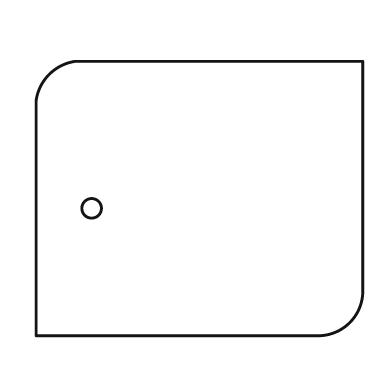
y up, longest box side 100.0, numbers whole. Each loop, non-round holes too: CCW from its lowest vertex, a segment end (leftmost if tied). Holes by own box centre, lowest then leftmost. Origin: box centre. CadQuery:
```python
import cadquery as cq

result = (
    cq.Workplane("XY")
    .moveTo(-50.0, -42.0)
    .lineTo(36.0, -42.0)
    .threePointArc((46.0, -38.0), (50.0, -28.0))
    .lineTo(50.0, 42.0)
    .lineTo(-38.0, 42.0)
    .threePointArc((-46.0, 38.0), (-50.0, 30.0))
    .close()
    .moveTo(-33.0, -3.0)
    .circle(3.0)
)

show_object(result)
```